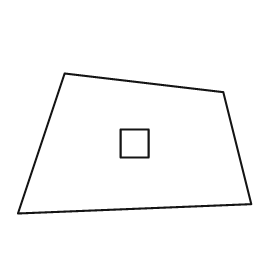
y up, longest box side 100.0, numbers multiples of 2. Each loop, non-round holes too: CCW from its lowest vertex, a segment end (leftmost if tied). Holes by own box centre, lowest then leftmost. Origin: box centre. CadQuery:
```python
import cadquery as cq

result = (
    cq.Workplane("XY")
    .moveTo(-50.0, -30.0)
    .lineTo(50.0, -26.0)
    .lineTo(38.0, 22.0)
    .lineTo(-30.0, 30.0)
    .close()
    .moveTo(-6.0, -6.0)
    .lineTo(6.0, -6.0)
    .lineTo(6.0, 6.0)
    .lineTo(-6.0, 6.0)
    .close()
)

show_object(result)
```